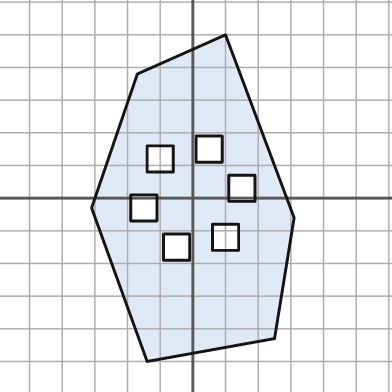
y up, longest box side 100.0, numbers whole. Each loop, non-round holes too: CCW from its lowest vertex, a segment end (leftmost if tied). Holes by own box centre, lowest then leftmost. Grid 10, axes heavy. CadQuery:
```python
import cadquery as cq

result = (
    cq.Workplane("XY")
    .moveTo(-14.0, -50.0)
    .lineTo(25.0, -43.0)
    .lineTo(31.0, -6.0)
    .lineTo(10.0, 50.0)
    .lineTo(-17.0, 38.0)
    .lineTo(-31.0, -3.0)
    .close()
    .moveTo(-9.0, -19.0)
    .lineTo(-1.0, -19.0)
    .lineTo(-1.0, -11.0)
    .lineTo(-9.0, -11.0)
    .close()
    .moveTo(6.0, -16.0)
    .lineTo(14.0, -16.0)
    .lineTo(14.0, -8.0)
    .lineTo(6.0, -8.0)
    .close()
    .moveTo(-19.0, -7.0)
    .lineTo(-11.0, -7.0)
    .lineTo(-11.0, 1.0)
    .lineTo(-19.0, 1.0)
    .close()
    .moveTo(11.0, -1.0)
    .lineTo(19.0, -1.0)
    .lineTo(19.0, 7.0)
    .lineTo(11.0, 7.0)
    .close()
    .moveTo(-14.0, 8.0)
    .lineTo(-6.0, 8.0)
    .lineTo(-6.0, 16.0)
    .lineTo(-14.0, 16.0)
    .close()
    .moveTo(1.0, 11.0)
    .lineTo(9.0, 11.0)
    .lineTo(9.0, 19.0)
    .lineTo(1.0, 19.0)
    .close()
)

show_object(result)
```